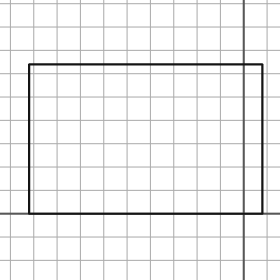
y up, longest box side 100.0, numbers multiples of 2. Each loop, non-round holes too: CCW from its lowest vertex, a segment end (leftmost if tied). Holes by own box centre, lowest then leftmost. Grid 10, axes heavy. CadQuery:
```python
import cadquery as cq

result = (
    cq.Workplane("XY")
    .moveTo(-92.0, 0.0)
    .lineTo(8.0, 0.0)
    .lineTo(8.0, 64.0)
    .lineTo(-92.0, 64.0)
    .close()
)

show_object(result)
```